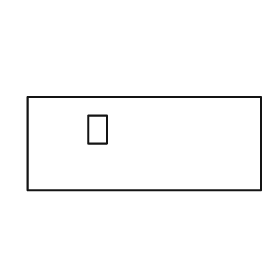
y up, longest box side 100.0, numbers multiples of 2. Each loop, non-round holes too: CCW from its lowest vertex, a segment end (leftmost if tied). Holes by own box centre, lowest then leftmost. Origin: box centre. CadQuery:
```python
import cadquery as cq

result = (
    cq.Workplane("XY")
    .moveTo(-50.0, -20.0)
    .lineTo(50.0, -20.0)
    .lineTo(50.0, 20.0)
    .lineTo(-50.0, 20.0)
    .close()
    .moveTo(-24.0, 0.0)
    .lineTo(-16.0, 0.0)
    .lineTo(-16.0, 12.0)
    .lineTo(-24.0, 12.0)
    .close()
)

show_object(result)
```